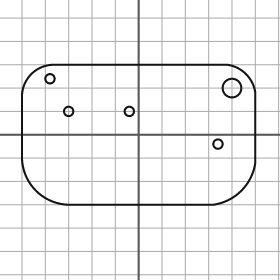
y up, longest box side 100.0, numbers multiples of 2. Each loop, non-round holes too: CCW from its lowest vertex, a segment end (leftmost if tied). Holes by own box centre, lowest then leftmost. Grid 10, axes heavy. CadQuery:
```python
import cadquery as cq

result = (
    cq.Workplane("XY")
    .moveTo(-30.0, -30.0)
    .lineTo(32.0, -30.0)
    .threePointArc((44.0, -24.0), (50.0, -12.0))
    .lineTo(50.0, 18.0)
    .threePointArc((46.0, 26.0), (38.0, 30.0))
    .lineTo(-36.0, 30.0)
    .threePointArc((-46.0, 26.0), (-50.0, 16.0))
    .lineTo(-50.0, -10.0)
    .threePointArc((-44.0, -24.0), (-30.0, -30.0))
    .close()
    .moveTo(34.0, -4.0)
    .circle(2.0)
    .moveTo(-30.0, 10.0)
    .circle(2.0)
    .moveTo(-4.0, 10.0)
    .circle(2.0)
    .moveTo(40.0, 20.0)
    .circle(4.0)
    .moveTo(-38.0, 24.0)
    .circle(2.0)
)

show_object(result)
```